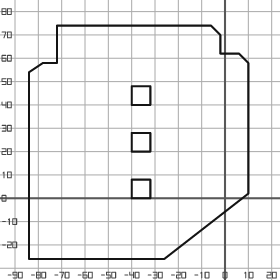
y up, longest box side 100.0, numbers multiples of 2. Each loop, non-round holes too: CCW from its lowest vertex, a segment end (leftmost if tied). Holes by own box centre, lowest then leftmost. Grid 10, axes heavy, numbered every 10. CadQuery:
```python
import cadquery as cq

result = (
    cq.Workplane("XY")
    .moveTo(-84.0, -26.0)
    .lineTo(-26.0, -26.0)
    .lineTo(10.0, 2.0)
    .lineTo(10.0, 58.0)
    .lineTo(6.0, 62.0)
    .lineTo(-2.0, 62.0)
    .lineTo(-2.0, 70.0)
    .lineTo(-6.0, 74.0)
    .lineTo(-72.0, 74.0)
    .lineTo(-72.0, 58.0)
    .lineTo(-78.0, 58.0)
    .lineTo(-84.0, 54.0)
    .close()
    .moveTo(-40.0, 0.0)
    .lineTo(-32.0, 0.0)
    .lineTo(-32.0, 8.0)
    .lineTo(-40.0, 8.0)
    .close()
    .moveTo(-40.0, 20.0)
    .lineTo(-32.0, 20.0)
    .lineTo(-32.0, 28.0)
    .lineTo(-40.0, 28.0)
    .close()
    .moveTo(-40.0, 40.0)
    .lineTo(-32.0, 40.0)
    .lineTo(-32.0, 48.0)
    .lineTo(-40.0, 48.0)
    .close()
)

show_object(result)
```